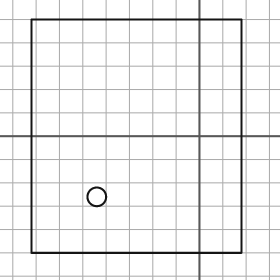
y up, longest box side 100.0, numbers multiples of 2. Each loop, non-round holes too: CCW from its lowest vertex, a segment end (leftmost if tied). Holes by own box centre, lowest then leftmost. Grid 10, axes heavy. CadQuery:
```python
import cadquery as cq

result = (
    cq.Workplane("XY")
    .moveTo(-72.0, -50.0)
    .lineTo(18.0, -50.0)
    .lineTo(18.0, 50.0)
    .lineTo(-72.0, 50.0)
    .close()
    .moveTo(-44.0, -26.0)
    .circle(4.0)
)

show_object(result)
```